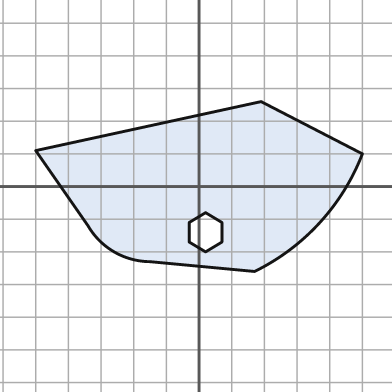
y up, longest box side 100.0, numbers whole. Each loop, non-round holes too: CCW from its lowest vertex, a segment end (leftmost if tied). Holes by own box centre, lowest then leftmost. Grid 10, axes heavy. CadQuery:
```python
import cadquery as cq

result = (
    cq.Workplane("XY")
    .moveTo(17.0, -26.0)
    .threePointArc((37.0, -11.0), (50.0, 10.0))
    .lineTo(19.0, 26.0)
    .lineTo(-50.0, 11.0)
    .lineTo(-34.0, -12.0)
    .threePointArc((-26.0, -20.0), (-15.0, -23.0))
    .close()
    .moveTo(2.0, -20.0)
    .lineTo(7.0, -17.0)
    .lineTo(7.0, -11.0)
    .lineTo(2.0, -8.0)
    .lineTo(-3.0, -11.0)
    .lineTo(-3.0, -17.0)
    .close()
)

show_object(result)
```